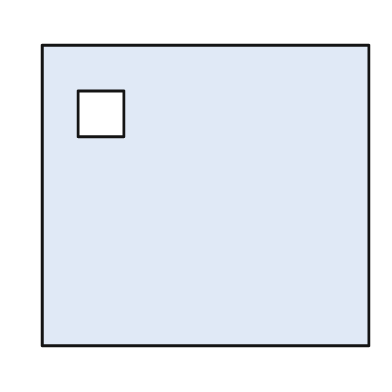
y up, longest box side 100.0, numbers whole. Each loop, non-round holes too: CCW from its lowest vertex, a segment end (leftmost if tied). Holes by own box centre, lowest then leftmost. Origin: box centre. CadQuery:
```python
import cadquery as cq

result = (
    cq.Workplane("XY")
    .moveTo(-50.0, -46.0)
    .lineTo(50.0, -46.0)
    .lineTo(50.0, 46.0)
    .lineTo(-50.0, 46.0)
    .close()
    .moveTo(-39.0, 18.0)
    .lineTo(-25.0, 18.0)
    .lineTo(-25.0, 32.0)
    .lineTo(-39.0, 32.0)
    .close()
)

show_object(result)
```